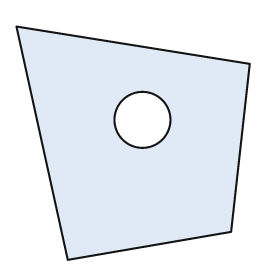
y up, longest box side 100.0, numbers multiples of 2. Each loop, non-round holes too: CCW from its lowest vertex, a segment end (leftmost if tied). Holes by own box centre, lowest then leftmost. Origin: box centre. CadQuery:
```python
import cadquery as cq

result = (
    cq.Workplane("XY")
    .moveTo(-28.0, -50.0)
    .lineTo(42.0, -38.0)
    .lineTo(50.0, 34.0)
    .lineTo(-50.0, 50.0)
    .close()
    .moveTo(4.0, 10.0)
    .circle(12.0)
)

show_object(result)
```